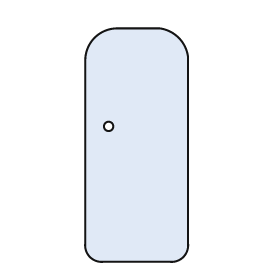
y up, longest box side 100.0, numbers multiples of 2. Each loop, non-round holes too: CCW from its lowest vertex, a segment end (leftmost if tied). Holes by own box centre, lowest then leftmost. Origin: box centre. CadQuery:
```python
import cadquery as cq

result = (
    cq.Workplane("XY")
    .moveTo(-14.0, -50.0)
    .lineTo(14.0, -50.0)
    .threePointArc((20.0, -48.0), (22.0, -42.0))
    .lineTo(22.0, 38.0)
    .threePointArc((18.0, 46.0), (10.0, 50.0))
    .lineTo(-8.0, 50.0)
    .threePointArc((-18.0, 46.0), (-22.0, 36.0))
    .lineTo(-22.0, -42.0)
    .threePointArc((-20.0, -48.0), (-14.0, -50.0))
    .close()
    .moveTo(-12.0, 8.0)
    .circle(2.0)
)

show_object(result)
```